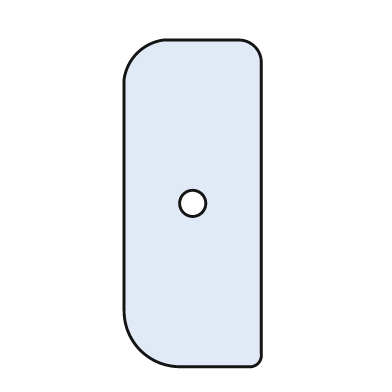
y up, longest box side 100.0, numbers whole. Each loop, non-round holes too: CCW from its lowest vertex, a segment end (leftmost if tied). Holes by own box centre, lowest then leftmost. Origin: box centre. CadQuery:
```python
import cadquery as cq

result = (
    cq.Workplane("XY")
    .moveTo(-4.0, -50.0)
    .lineTo(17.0, -50.0)
    .threePointArc((20.0, -49.0), (21.0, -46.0))
    .lineTo(21.0, 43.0)
    .threePointArc((19.0, 48.0), (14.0, 50.0))
    .lineTo(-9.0, 50.0)
    .threePointArc((-17.0, 46.0), (-21.0, 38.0))
    .lineTo(-21.0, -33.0)
    .threePointArc((-16.0, -45.0), (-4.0, -50.0))
    .close()
    .moveTo(0.0, 0.0)
    .circle(4.0)
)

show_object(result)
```